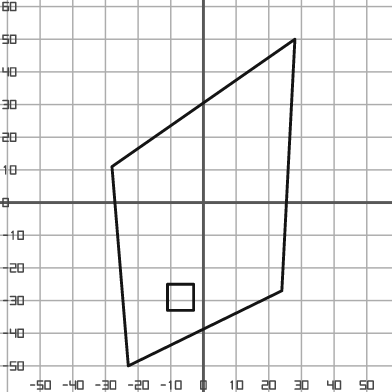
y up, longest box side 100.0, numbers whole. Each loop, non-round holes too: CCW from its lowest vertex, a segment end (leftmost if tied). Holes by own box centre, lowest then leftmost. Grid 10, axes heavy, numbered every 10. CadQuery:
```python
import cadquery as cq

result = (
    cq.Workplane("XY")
    .moveTo(-23.0, -50.0)
    .lineTo(24.0, -27.0)
    .lineTo(28.0, 50.0)
    .lineTo(-28.0, 11.0)
    .close()
    .moveTo(-11.0, -33.0)
    .lineTo(-3.0, -33.0)
    .lineTo(-3.0, -25.0)
    .lineTo(-11.0, -25.0)
    .close()
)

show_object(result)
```